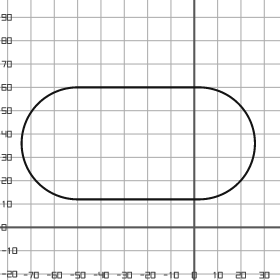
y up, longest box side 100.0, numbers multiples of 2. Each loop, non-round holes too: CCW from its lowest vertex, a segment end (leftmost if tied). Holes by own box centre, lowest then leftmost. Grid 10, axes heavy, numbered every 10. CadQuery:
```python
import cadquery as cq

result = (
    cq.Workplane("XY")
    .moveTo(-50.0, 12.0)
    .lineTo(2.0, 12.0)
    .threePointArc((26.0, 36.0), (2.0, 60.0))
    .lineTo(-50.0, 60.0)
    .threePointArc((-74.0, 36.0), (-50.0, 12.0))
    .close()
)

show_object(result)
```